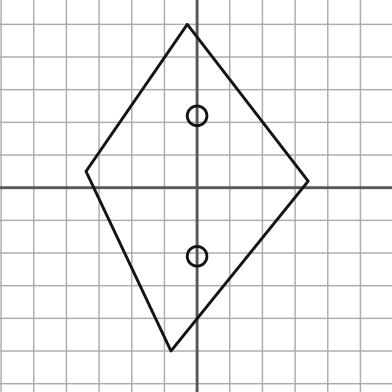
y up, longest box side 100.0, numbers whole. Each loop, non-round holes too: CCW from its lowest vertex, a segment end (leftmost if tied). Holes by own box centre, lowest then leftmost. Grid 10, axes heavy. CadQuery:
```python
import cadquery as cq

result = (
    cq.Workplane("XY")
    .moveTo(-8.0, -50.0)
    .lineTo(34.0, 2.0)
    .lineTo(-3.0, 50.0)
    .lineTo(-34.0, 5.0)
    .close()
    .moveTo(0.0, -21.0)
    .circle(3.0)
    .moveTo(0.0, 22.0)
    .circle(3.0)
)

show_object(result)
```